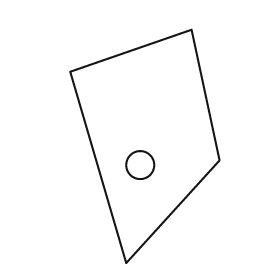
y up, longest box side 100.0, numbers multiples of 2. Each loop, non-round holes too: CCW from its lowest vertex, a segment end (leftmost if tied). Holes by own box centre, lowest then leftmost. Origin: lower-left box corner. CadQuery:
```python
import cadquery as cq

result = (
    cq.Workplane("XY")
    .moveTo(24.0, 0.0)
    .lineTo(64.0, 44.0)
    .lineTo(52.0, 100.0)
    .lineTo(0.0, 82.0)
    .close()
    .moveTo(30.0, 42.0)
    .circle(6.0)
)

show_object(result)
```